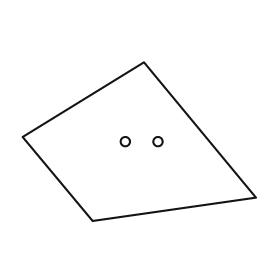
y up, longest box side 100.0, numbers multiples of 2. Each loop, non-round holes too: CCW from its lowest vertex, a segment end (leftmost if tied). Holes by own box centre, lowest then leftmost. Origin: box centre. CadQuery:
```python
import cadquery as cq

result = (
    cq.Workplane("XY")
    .moveTo(-20.0, -34.0)
    .lineTo(50.0, -24.0)
    .lineTo(2.0, 34.0)
    .lineTo(-50.0, 2.0)
    .close()
    .moveTo(-6.0, 0.0)
    .circle(2.0)
    .moveTo(8.0, 0.0)
    .circle(2.0)
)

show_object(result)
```